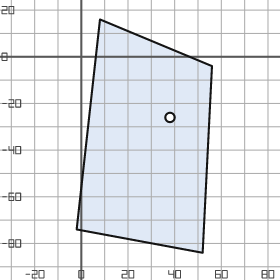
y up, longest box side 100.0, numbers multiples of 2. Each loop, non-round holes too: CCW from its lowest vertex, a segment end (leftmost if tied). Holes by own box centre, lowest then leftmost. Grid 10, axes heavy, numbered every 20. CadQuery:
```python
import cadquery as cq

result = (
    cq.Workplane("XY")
    .moveTo(52.0, -84.0)
    .lineTo(56.0, -4.0)
    .lineTo(8.0, 16.0)
    .lineTo(-2.0, -74.0)
    .close()
    .moveTo(38.0, -26.0)
    .circle(2.0)
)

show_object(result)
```